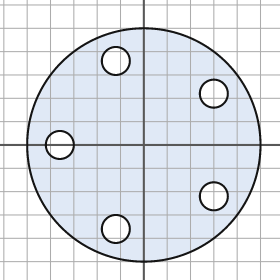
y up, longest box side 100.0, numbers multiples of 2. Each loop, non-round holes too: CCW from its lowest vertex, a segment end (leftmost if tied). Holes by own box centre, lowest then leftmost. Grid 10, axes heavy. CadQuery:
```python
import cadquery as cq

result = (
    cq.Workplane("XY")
    .moveTo(0.0, 0.0)
    .circle(50.0)
    .moveTo(-12.0, -36.0)
    .circle(6.0)
    .moveTo(30.0, -22.0)
    .circle(6.0)
    .moveTo(-36.0, 0.0)
    .circle(6.0)
    .moveTo(30.0, 22.0)
    .circle(6.0)
    .moveTo(-12.0, 36.0)
    .circle(6.0)
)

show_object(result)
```